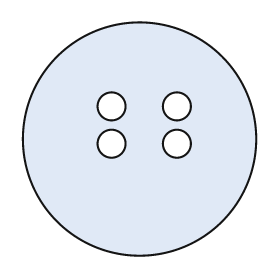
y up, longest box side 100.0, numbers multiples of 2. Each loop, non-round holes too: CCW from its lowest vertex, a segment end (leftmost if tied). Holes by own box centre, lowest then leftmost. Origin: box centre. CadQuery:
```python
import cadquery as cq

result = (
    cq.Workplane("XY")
    .moveTo(0.0, 0.0)
    .circle(50.0)
    .moveTo(-12.0, -2.0)
    .circle(6.0)
    .moveTo(16.0, -2.0)
    .circle(6.0)
    .moveTo(-12.0, 14.0)
    .circle(6.0)
    .moveTo(16.0, 14.0)
    .circle(6.0)
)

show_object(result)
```